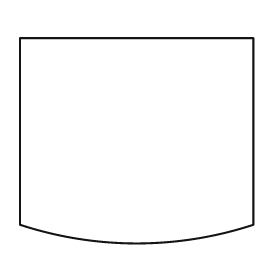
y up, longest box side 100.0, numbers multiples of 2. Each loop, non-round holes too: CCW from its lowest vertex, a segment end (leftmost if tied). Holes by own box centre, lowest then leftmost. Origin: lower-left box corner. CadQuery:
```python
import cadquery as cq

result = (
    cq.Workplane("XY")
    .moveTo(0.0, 8.0)
    .threePointArc((50.0, 0.0), (100.0, 8.0))
    .lineTo(100.0, 88.0)
    .lineTo(0.0, 88.0)
    .close()
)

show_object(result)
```